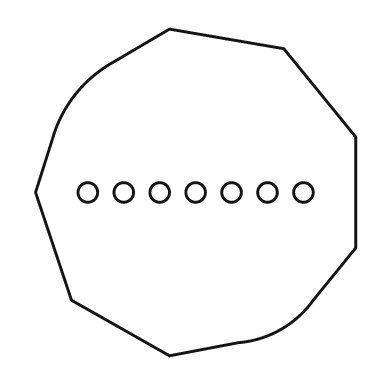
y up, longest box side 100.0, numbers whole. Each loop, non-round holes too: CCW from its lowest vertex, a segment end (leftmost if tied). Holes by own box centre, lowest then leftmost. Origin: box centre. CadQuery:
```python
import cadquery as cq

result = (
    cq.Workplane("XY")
    .moveTo(-8.0, -50.0)
    .lineTo(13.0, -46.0)
    .threePointArc((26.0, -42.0), (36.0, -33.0))
    .lineTo(49.0, -17.0)
    .lineTo(49.0, 17.0)
    .lineTo(27.0, 44.0)
    .lineTo(-8.0, 50.0)
    .lineTo(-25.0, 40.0)
    .threePointArc((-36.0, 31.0), (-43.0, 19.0))
    .lineTo(-49.0, 0.0)
    .lineTo(-38.0, -33.0)
    .close()
    .moveTo(-33.0, 0.0)
    .circle(3.0)
    .moveTo(-22.0, 0.0)
    .circle(3.0)
    .moveTo(-11.0, 0.0)
    .circle(3.0)
    .moveTo(0.0, 0.0)
    .circle(3.0)
    .moveTo(11.0, 0.0)
    .circle(3.0)
    .moveTo(22.0, 0.0)
    .circle(3.0)
    .moveTo(33.0, 0.0)
    .circle(3.0)
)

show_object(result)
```